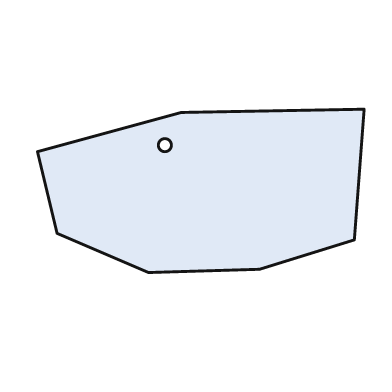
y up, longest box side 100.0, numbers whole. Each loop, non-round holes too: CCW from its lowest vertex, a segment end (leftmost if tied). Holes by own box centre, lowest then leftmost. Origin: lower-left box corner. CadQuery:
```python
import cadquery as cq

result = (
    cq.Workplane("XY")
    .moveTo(34.0, 0.0)
    .lineTo(68.0, 1.0)
    .lineTo(97.0, 10.0)
    .lineTo(100.0, 50.0)
    .lineTo(44.0, 49.0)
    .lineTo(0.0, 37.0)
    .lineTo(6.0, 12.0)
    .close()
    .moveTo(39.0, 39.0)
    .circle(2.0)
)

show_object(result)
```